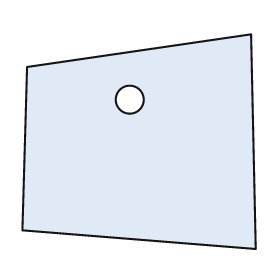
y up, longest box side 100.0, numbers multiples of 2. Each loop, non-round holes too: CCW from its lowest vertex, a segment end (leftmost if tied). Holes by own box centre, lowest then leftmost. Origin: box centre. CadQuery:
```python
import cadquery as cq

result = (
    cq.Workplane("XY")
    .moveTo(50.0, -46.0)
    .lineTo(48.0, 46.0)
    .lineTo(-48.0, 32.0)
    .lineTo(-50.0, -38.0)
    .close()
    .moveTo(-4.0, 18.0)
    .circle(6.0)
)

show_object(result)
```